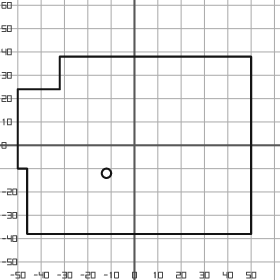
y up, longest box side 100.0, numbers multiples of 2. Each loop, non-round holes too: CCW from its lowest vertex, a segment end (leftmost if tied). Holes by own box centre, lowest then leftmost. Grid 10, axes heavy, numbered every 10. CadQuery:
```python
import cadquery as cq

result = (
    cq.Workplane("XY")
    .moveTo(-46.0, -38.0)
    .lineTo(50.0, -38.0)
    .lineTo(50.0, 38.0)
    .lineTo(-32.0, 38.0)
    .lineTo(-32.0, 24.0)
    .lineTo(-50.0, 24.0)
    .lineTo(-50.0, -10.0)
    .lineTo(-46.0, -10.0)
    .close()
    .moveTo(-12.0, -12.0)
    .circle(2.0)
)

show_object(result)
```